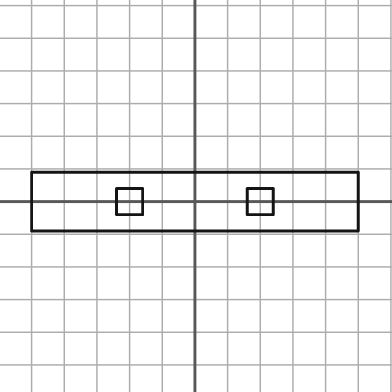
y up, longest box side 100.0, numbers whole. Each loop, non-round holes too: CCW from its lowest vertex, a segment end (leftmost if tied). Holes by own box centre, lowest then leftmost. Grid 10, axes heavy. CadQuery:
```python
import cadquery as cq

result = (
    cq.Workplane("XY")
    .moveTo(-50.0, -9.0)
    .lineTo(50.0, -9.0)
    .lineTo(50.0, 9.0)
    .lineTo(-50.0, 9.0)
    .close()
    .moveTo(-24.0, -4.0)
    .lineTo(-16.0, -4.0)
    .lineTo(-16.0, 4.0)
    .lineTo(-24.0, 4.0)
    .close()
    .moveTo(16.0, -4.0)
    .lineTo(24.0, -4.0)
    .lineTo(24.0, 4.0)
    .lineTo(16.0, 4.0)
    .close()
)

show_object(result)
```